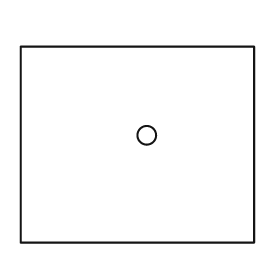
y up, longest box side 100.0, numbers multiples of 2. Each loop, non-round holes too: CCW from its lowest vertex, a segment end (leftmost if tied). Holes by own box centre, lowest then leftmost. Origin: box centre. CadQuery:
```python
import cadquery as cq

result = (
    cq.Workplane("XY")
    .moveTo(-50.0, -42.0)
    .lineTo(50.0, -42.0)
    .lineTo(50.0, 42.0)
    .lineTo(-50.0, 42.0)
    .close()
    .moveTo(4.0, 4.0)
    .circle(4.0)
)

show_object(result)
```